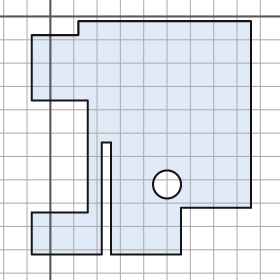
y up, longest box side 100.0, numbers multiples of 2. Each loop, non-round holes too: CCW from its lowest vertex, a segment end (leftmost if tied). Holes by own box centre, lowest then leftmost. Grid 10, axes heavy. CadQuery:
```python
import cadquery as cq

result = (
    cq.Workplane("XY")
    .moveTo(-8.0, -102.0)
    .lineTo(22.0, -102.0)
    .lineTo(22.0, -54.0)
    .lineTo(26.0, -54.0)
    .lineTo(26.0, -102.0)
    .lineTo(56.0, -102.0)
    .lineTo(56.0, -82.0)
    .lineTo(86.0, -82.0)
    .lineTo(86.0, -2.0)
    .lineTo(12.0, -2.0)
    .lineTo(12.0, -8.0)
    .lineTo(-8.0, -8.0)
    .lineTo(-8.0, -36.0)
    .lineTo(16.0, -36.0)
    .lineTo(16.0, -84.0)
    .lineTo(-8.0, -84.0)
    .close()
    .moveTo(50.0, -72.0)
    .circle(6.0)
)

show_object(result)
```